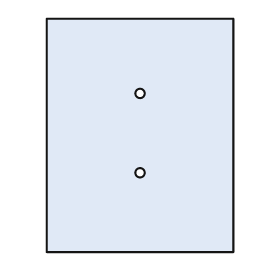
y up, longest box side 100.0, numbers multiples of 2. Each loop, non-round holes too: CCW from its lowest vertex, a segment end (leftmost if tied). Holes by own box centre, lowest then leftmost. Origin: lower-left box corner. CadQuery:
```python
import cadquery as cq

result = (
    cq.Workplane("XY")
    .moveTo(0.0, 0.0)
    .lineTo(80.0, 0.0)
    .lineTo(80.0, 100.0)
    .lineTo(0.0, 100.0)
    .close()
    .moveTo(40.0, 34.0)
    .circle(2.0)
    .moveTo(40.0, 68.0)
    .circle(2.0)
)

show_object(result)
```